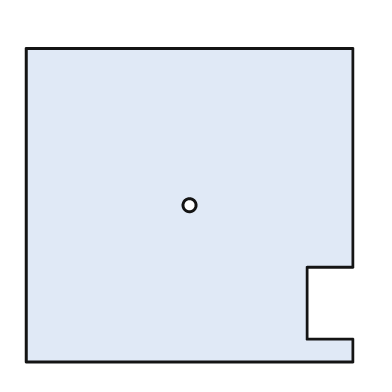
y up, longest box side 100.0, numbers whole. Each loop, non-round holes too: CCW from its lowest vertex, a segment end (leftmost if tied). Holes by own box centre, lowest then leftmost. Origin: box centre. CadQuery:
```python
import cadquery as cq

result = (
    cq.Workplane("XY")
    .moveTo(-50.0, -48.0)
    .lineTo(50.0, -48.0)
    .lineTo(50.0, -41.0)
    .lineTo(36.0, -41.0)
    .lineTo(36.0, -19.0)
    .lineTo(50.0, -19.0)
    .lineTo(50.0, 48.0)
    .lineTo(-50.0, 48.0)
    .close()
    .moveTo(0.0, 0.0)
    .circle(2.0)
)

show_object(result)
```